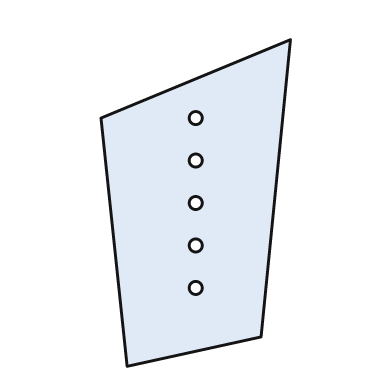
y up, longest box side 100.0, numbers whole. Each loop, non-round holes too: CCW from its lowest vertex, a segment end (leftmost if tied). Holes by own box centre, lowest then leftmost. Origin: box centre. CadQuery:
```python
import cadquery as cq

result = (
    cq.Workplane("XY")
    .moveTo(-21.0, -50.0)
    .lineTo(20.0, -41.0)
    .lineTo(29.0, 50.0)
    .lineTo(-29.0, 26.0)
    .close()
    .moveTo(0.0, -26.0)
    .circle(2.0)
    .moveTo(0.0, -13.0)
    .circle(2.0)
    .moveTo(0.0, 0.0)
    .circle(2.0)
    .moveTo(0.0, 13.0)
    .circle(2.0)
    .moveTo(0.0, 26.0)
    .circle(2.0)
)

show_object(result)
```